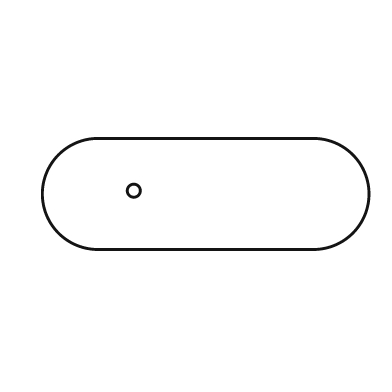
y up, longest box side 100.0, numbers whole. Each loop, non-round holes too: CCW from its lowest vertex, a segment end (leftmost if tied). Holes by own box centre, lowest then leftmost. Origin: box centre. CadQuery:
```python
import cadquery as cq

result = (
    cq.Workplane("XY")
    .moveTo(-33.0, -17.0)
    .lineTo(33.0, -17.0)
    .threePointArc((50.0, 0.0), (33.0, 17.0))
    .lineTo(-33.0, 17.0)
    .threePointArc((-50.0, 0.0), (-33.0, -17.0))
    .close()
    .moveTo(-22.0, 1.0)
    .circle(2.0)
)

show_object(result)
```